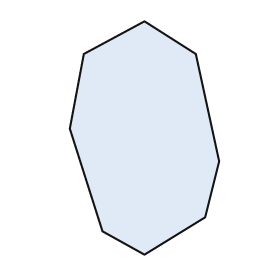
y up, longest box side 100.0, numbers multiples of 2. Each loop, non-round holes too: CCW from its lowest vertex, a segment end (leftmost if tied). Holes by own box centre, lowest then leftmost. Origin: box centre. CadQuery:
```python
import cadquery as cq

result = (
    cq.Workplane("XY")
    .moveTo(0.0, -50.0)
    .lineTo(26.0, -34.0)
    .lineTo(32.0, -10.0)
    .lineTo(22.0, 36.0)
    .lineTo(0.0, 50.0)
    .lineTo(-26.0, 36.0)
    .lineTo(-32.0, 4.0)
    .lineTo(-18.0, -40.0)
    .close()
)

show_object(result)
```